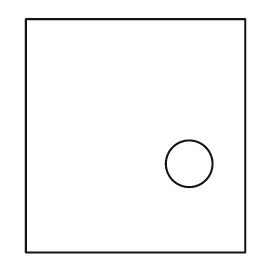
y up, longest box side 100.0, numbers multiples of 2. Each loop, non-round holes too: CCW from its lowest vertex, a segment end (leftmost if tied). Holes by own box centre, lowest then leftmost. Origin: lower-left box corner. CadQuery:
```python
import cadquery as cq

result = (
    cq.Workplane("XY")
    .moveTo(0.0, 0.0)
    .lineTo(94.0, 0.0)
    .lineTo(94.0, 100.0)
    .lineTo(0.0, 100.0)
    .close()
    .moveTo(70.0, 38.0)
    .circle(10.0)
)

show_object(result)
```